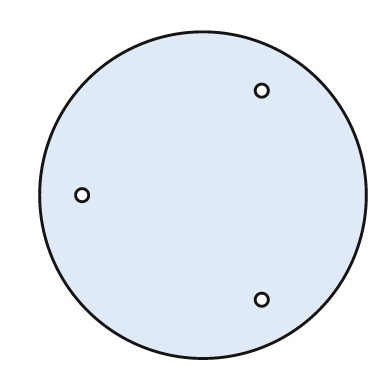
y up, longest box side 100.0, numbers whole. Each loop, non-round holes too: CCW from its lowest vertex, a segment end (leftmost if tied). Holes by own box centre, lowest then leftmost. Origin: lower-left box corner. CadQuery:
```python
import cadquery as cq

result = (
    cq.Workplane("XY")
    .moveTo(50.0, 50.0)
    .circle(50.0)
    .moveTo(68.0, 18.0)
    .circle(2.0)
    .moveTo(13.0, 50.0)
    .circle(2.0)
    .moveTo(68.0, 82.0)
    .circle(2.0)
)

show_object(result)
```